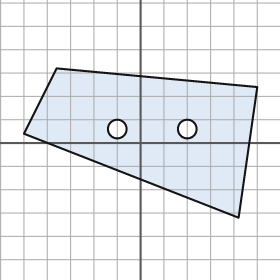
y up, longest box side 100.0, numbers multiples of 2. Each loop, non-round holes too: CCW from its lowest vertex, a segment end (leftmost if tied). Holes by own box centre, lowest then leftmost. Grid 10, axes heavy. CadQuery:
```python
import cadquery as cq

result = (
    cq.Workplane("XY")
    .moveTo(42.0, -32.0)
    .lineTo(50.0, 24.0)
    .lineTo(-36.0, 32.0)
    .lineTo(-50.0, 4.0)
    .close()
    .moveTo(-10.0, 6.0)
    .circle(4.0)
    .moveTo(20.0, 6.0)
    .circle(4.0)
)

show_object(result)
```